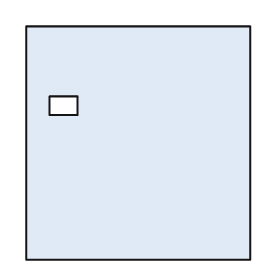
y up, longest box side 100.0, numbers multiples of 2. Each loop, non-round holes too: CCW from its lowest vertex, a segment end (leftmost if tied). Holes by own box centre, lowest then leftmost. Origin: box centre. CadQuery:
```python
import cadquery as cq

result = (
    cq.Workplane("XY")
    .moveTo(-48.0, -50.0)
    .lineTo(48.0, -50.0)
    .lineTo(48.0, 50.0)
    .lineTo(-48.0, 50.0)
    .close()
    .moveTo(-38.0, 12.0)
    .lineTo(-26.0, 12.0)
    .lineTo(-26.0, 20.0)
    .lineTo(-38.0, 20.0)
    .close()
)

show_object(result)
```